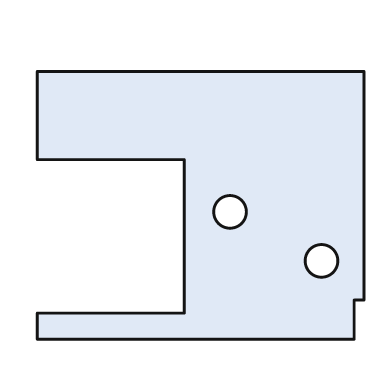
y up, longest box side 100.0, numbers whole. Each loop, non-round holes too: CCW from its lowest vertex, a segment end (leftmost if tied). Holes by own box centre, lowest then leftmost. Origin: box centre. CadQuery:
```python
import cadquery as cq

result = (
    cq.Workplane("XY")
    .moveTo(-50.0, -41.0)
    .lineTo(47.0, -41.0)
    .lineTo(47.0, -29.0)
    .lineTo(50.0, -29.0)
    .lineTo(50.0, 41.0)
    .lineTo(-50.0, 41.0)
    .lineTo(-50.0, 14.0)
    .lineTo(-5.0, 14.0)
    .lineTo(-5.0, -33.0)
    .lineTo(-50.0, -33.0)
    .close()
    .moveTo(37.0, -17.0)
    .circle(5.0)
    .moveTo(9.0, -2.0)
    .circle(5.0)
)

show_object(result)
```